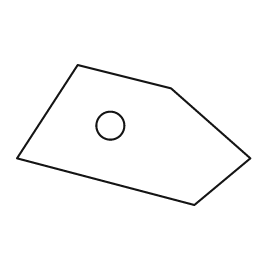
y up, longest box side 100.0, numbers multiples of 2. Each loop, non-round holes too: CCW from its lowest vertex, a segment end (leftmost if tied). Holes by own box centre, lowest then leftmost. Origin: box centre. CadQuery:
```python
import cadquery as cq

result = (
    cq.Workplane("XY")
    .moveTo(26.0, -30.0)
    .lineTo(50.0, -10.0)
    .lineTo(16.0, 20.0)
    .lineTo(-24.0, 30.0)
    .lineTo(-50.0, -10.0)
    .close()
    .moveTo(-10.0, 4.0)
    .circle(6.0)
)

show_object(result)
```